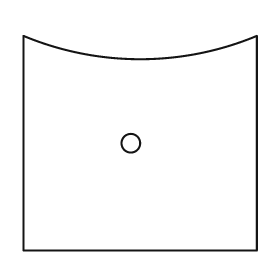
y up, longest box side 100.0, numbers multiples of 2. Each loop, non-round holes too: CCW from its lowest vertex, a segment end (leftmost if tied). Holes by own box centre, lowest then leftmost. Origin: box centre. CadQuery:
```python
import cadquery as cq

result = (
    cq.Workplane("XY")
    .moveTo(-50.0, -46.0)
    .lineTo(50.0, -46.0)
    .lineTo(50.0, 46.0)
    .threePointArc((0.0, 36.0), (-50.0, 46.0))
    .close()
    .moveTo(-4.0, 0.0)
    .circle(4.0)
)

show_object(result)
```